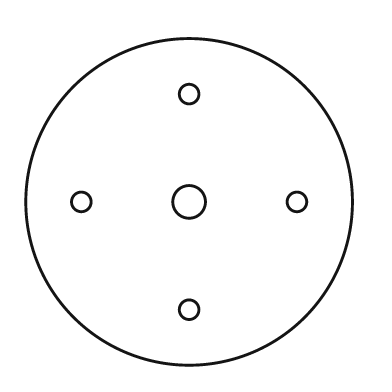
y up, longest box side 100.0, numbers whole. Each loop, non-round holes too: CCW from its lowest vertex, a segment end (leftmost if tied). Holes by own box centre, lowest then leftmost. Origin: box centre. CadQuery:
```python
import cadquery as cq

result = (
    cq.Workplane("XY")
    .moveTo(0.0, 0.0)
    .circle(50.0)
    .moveTo(0.0, -33.0)
    .circle(3.0)
    .moveTo(-33.0, 0.0)
    .circle(3.0)
    .moveTo(0.0, 0.0)
    .circle(5.0)
    .moveTo(33.0, 0.0)
    .circle(3.0)
    .moveTo(0.0, 33.0)
    .circle(3.0)
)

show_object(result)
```